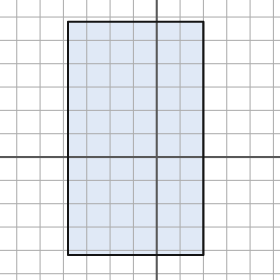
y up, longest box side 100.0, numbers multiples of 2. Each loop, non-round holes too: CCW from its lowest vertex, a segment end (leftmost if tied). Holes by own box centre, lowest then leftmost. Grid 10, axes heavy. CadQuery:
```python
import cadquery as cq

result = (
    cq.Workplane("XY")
    .moveTo(-38.0, -42.0)
    .lineTo(20.0, -42.0)
    .lineTo(20.0, 58.0)
    .lineTo(-38.0, 58.0)
    .close()
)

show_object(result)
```